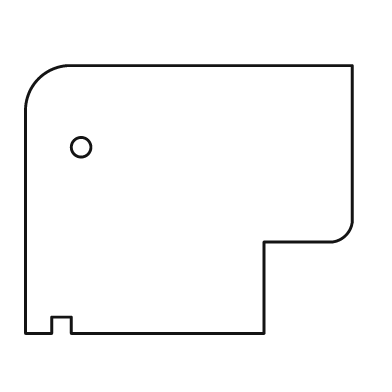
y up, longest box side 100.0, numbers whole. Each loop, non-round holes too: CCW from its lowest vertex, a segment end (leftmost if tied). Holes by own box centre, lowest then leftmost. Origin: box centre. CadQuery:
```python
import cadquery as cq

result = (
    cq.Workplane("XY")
    .moveTo(-50.0, -41.0)
    .lineTo(-42.0, -41.0)
    .lineTo(-42.0, -36.0)
    .lineTo(-36.0, -36.0)
    .lineTo(-36.0, -41.0)
    .lineTo(23.0, -41.0)
    .lineTo(23.0, -13.0)
    .lineTo(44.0, -13.0)
    .threePointArc((48.0, -11.0), (50.0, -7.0))
    .lineTo(50.0, 41.0)
    .lineTo(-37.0, 41.0)
    .threePointArc((-46.0, 37.0), (-50.0, 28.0))
    .close()
    .moveTo(-33.0, 16.0)
    .circle(3.0)
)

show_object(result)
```